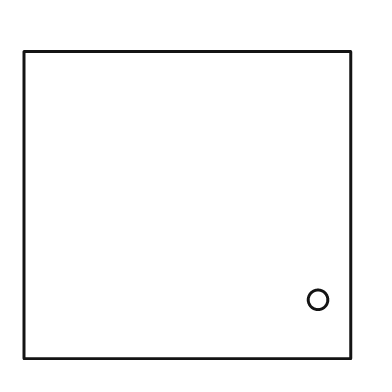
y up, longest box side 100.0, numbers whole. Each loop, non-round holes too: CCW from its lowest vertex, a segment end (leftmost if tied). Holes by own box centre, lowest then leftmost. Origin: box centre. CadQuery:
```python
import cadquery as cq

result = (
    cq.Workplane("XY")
    .moveTo(-50.0, -47.0)
    .lineTo(50.0, -47.0)
    .lineTo(50.0, 47.0)
    .lineTo(-50.0, 47.0)
    .close()
    .moveTo(40.0, -29.0)
    .circle(3.0)
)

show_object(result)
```